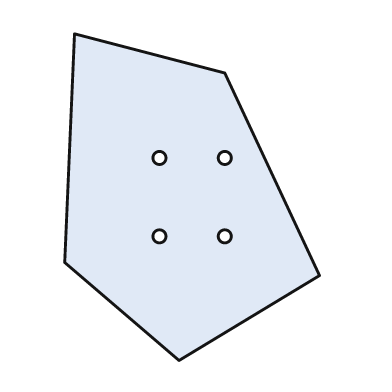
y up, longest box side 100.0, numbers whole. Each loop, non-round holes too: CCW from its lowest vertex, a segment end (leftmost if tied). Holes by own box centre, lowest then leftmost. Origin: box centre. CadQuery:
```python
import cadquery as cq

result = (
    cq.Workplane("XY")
    .moveTo(-4.0, -50.0)
    .lineTo(39.0, -24.0)
    .lineTo(10.0, 38.0)
    .lineTo(-36.0, 50.0)
    .lineTo(-39.0, -20.0)
    .close()
    .moveTo(-10.0, -12.0)
    .circle(2.0)
    .moveTo(10.0, -12.0)
    .circle(2.0)
    .moveTo(-10.0, 12.0)
    .circle(2.0)
    .moveTo(10.0, 12.0)
    .circle(2.0)
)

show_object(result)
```